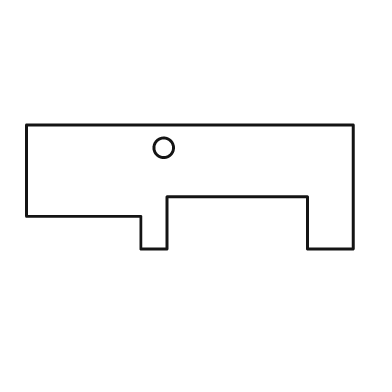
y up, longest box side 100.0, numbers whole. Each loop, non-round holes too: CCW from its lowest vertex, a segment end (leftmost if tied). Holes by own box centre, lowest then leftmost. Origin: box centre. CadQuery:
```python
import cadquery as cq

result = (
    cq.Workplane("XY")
    .moveTo(-15.0, -19.0)
    .lineTo(-7.0, -19.0)
    .lineTo(-7.0, -3.0)
    .lineTo(36.0, -3.0)
    .lineTo(36.0, -19.0)
    .lineTo(50.0, -19.0)
    .lineTo(50.0, 19.0)
    .lineTo(-50.0, 19.0)
    .lineTo(-50.0, -9.0)
    .lineTo(-15.0, -9.0)
    .close()
    .moveTo(-8.0, 12.0)
    .circle(3.0)
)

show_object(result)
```